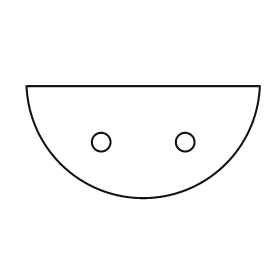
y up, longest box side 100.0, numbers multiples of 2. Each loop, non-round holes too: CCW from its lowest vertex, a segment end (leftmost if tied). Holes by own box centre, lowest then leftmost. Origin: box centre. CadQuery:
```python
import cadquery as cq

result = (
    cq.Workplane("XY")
    .moveTo(-50.0, 24.0)
    .threePointArc((0.0, -24.0), (50.0, 24.0))
    .close()
    .moveTo(-18.0, 0.0)
    .circle(4.0)
    .moveTo(18.0, 0.0)
    .circle(4.0)
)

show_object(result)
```